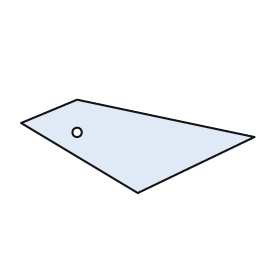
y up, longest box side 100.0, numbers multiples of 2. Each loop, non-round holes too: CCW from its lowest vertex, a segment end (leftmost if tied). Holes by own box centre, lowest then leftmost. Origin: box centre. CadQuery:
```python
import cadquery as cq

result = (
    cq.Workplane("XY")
    .moveTo(0.0, -20.0)
    .lineTo(50.0, 4.0)
    .lineTo(-26.0, 20.0)
    .lineTo(-50.0, 10.0)
    .close()
    .moveTo(-26.0, 6.0)
    .circle(2.0)
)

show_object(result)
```